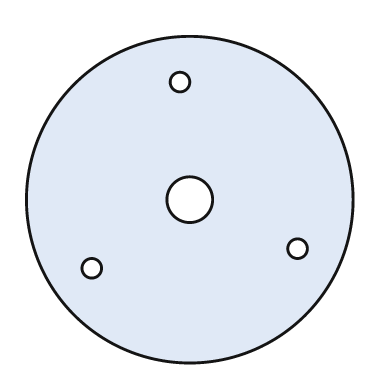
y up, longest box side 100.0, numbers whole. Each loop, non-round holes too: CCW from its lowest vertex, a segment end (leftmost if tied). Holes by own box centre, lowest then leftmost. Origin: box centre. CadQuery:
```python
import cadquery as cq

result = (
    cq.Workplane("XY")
    .moveTo(0.0, 0.0)
    .circle(50.0)
    .moveTo(-30.0, -21.0)
    .circle(3.0)
    .moveTo(33.0, -15.0)
    .circle(3.0)
    .moveTo(0.0, 0.0)
    .circle(7.0)
    .moveTo(-3.0, 36.0)
    .circle(3.0)
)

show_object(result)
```